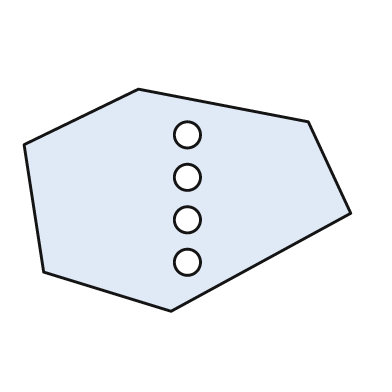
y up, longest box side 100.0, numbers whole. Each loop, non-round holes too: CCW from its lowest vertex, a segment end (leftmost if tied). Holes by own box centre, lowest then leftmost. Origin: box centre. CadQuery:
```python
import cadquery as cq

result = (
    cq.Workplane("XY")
    .moveTo(-5.0, -34.0)
    .lineTo(50.0, -4.0)
    .lineTo(37.0, 24.0)
    .lineTo(-15.0, 34.0)
    .lineTo(-50.0, 17.0)
    .lineTo(-44.0, -22.0)
    .close()
    .moveTo(0.0, -19.0)
    .circle(4.0)
    .moveTo(0.0, -6.0)
    .circle(4.0)
    .moveTo(0.0, 7.0)
    .circle(4.0)
    .moveTo(0.0, 20.0)
    .circle(4.0)
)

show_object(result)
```